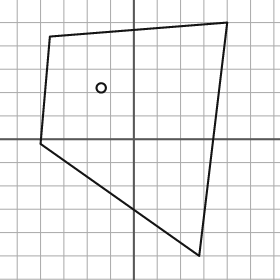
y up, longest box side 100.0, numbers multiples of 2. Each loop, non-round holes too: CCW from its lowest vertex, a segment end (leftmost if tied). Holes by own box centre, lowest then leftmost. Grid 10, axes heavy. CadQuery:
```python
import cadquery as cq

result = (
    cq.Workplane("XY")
    .moveTo(28.0, -50.0)
    .lineTo(40.0, 50.0)
    .lineTo(-36.0, 44.0)
    .lineTo(-40.0, -2.0)
    .close()
    .moveTo(-14.0, 22.0)
    .circle(2.0)
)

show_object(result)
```